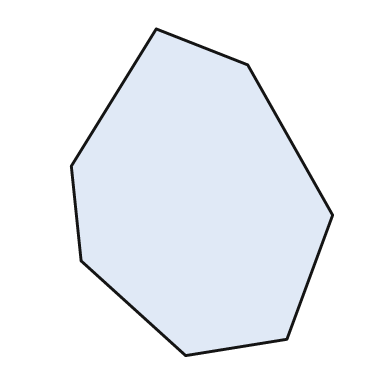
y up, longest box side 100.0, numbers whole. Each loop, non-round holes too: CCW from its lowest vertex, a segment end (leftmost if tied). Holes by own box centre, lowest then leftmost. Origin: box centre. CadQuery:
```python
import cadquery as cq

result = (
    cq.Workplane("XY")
    .moveTo(-5.0, -50.0)
    .lineTo(26.0, -45.0)
    .lineTo(40.0, -7.0)
    .lineTo(14.0, 39.0)
    .lineTo(-14.0, 50.0)
    .lineTo(-40.0, 8.0)
    .lineTo(-37.0, -21.0)
    .close()
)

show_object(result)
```